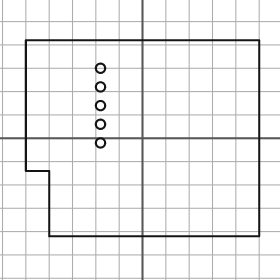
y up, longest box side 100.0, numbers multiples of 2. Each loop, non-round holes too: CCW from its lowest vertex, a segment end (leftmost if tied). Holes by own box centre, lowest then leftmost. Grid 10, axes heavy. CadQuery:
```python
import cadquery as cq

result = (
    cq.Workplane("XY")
    .moveTo(-40.0, -42.0)
    .lineTo(50.0, -42.0)
    .lineTo(50.0, 42.0)
    .lineTo(-50.0, 42.0)
    .lineTo(-50.0, -14.0)
    .lineTo(-40.0, -14.0)
    .close()
    .moveTo(-18.0, -2.0)
    .circle(2.0)
    .moveTo(-18.0, 6.0)
    .circle(2.0)
    .moveTo(-18.0, 14.0)
    .circle(2.0)
    .moveTo(-18.0, 22.0)
    .circle(2.0)
    .moveTo(-18.0, 30.0)
    .circle(2.0)
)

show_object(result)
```